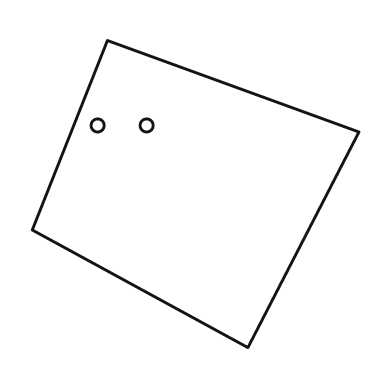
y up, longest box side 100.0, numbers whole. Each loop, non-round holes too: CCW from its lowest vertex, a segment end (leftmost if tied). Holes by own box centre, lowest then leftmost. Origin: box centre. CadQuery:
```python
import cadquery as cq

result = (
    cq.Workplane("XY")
    .moveTo(16.0, -47.0)
    .lineTo(50.0, 19.0)
    .lineTo(-27.0, 47.0)
    .lineTo(-50.0, -11.0)
    .close()
    .moveTo(-30.0, 21.0)
    .circle(2.0)
    .moveTo(-15.0, 21.0)
    .circle(2.0)
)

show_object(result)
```